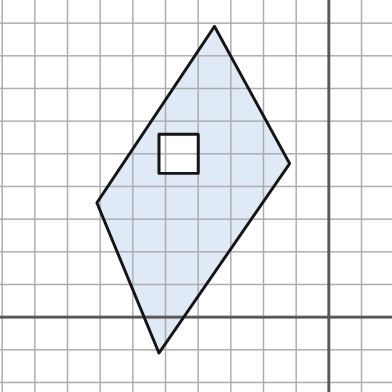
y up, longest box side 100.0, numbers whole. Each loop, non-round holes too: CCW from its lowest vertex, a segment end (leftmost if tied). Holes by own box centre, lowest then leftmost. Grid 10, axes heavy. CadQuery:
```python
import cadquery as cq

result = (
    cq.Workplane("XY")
    .moveTo(-52.0, -11.0)
    .lineTo(-12.0, 47.0)
    .lineTo(-35.0, 89.0)
    .lineTo(-71.0, 35.0)
    .close()
    .moveTo(-52.0, 44.0)
    .lineTo(-40.0, 44.0)
    .lineTo(-40.0, 56.0)
    .lineTo(-52.0, 56.0)
    .close()
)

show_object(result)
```